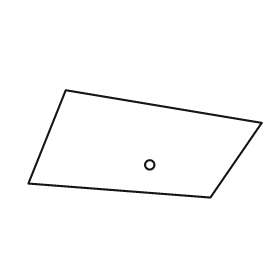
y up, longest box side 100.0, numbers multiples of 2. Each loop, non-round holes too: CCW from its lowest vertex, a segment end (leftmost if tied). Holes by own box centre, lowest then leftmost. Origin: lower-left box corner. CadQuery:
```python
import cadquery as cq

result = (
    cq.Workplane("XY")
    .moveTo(78.0, 0.0)
    .lineTo(100.0, 32.0)
    .lineTo(16.0, 46.0)
    .lineTo(0.0, 6.0)
    .close()
    .moveTo(52.0, 14.0)
    .circle(2.0)
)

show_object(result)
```